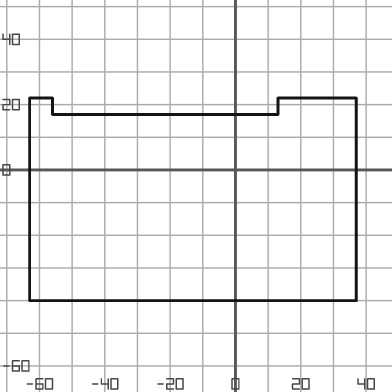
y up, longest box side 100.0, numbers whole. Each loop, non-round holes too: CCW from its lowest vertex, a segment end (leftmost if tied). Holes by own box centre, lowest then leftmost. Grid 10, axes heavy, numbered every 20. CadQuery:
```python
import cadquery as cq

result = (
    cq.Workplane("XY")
    .moveTo(-63.0, -40.0)
    .lineTo(37.0, -40.0)
    .lineTo(37.0, 22.0)
    .lineTo(13.0, 22.0)
    .lineTo(13.0, 17.0)
    .lineTo(-56.0, 17.0)
    .lineTo(-56.0, 22.0)
    .lineTo(-63.0, 22.0)
    .close()
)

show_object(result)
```